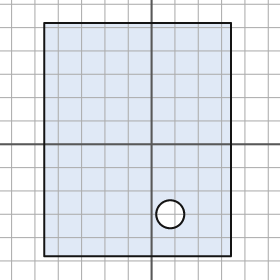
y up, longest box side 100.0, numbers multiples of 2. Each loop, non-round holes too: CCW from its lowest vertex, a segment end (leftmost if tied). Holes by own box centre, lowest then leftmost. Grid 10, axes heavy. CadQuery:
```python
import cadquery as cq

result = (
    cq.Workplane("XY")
    .moveTo(-46.0, -48.0)
    .lineTo(34.0, -48.0)
    .lineTo(34.0, 52.0)
    .lineTo(-46.0, 52.0)
    .close()
    .moveTo(8.0, -30.0)
    .circle(6.0)
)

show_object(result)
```